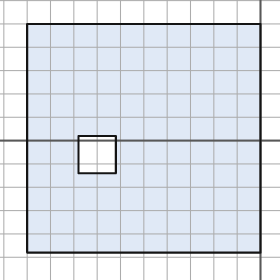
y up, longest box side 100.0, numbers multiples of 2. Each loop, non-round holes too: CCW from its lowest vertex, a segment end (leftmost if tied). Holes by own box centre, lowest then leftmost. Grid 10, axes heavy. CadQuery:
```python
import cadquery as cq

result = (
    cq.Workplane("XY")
    .moveTo(-100.0, -48.0)
    .lineTo(0.0, -48.0)
    .lineTo(0.0, 50.0)
    .lineTo(-100.0, 50.0)
    .close()
    .moveTo(-78.0, -14.0)
    .lineTo(-62.0, -14.0)
    .lineTo(-62.0, 2.0)
    .lineTo(-78.0, 2.0)
    .close()
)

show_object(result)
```